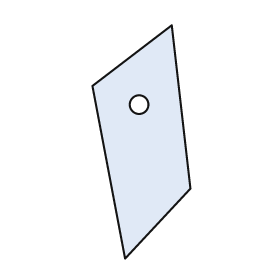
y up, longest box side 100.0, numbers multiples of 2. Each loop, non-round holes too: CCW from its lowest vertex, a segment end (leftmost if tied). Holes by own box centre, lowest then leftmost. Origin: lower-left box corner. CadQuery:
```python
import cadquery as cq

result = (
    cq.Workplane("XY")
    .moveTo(14.0, 0.0)
    .lineTo(42.0, 30.0)
    .lineTo(34.0, 100.0)
    .lineTo(0.0, 74.0)
    .close()
    .moveTo(20.0, 66.0)
    .circle(4.0)
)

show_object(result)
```